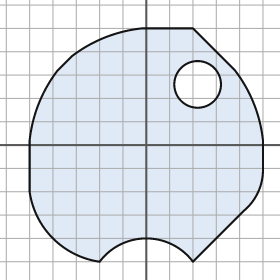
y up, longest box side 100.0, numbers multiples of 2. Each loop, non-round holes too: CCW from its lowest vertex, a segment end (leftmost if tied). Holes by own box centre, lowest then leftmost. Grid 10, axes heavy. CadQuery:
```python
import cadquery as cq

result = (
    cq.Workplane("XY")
    .moveTo(-20.0, -50.0)
    .threePointArc((0.0, -40.0), (20.0, -50.0))
    .lineTo(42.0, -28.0)
    .threePointArc((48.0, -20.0), (50.0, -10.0))
    .lineTo(50.0, 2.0)
    .threePointArc((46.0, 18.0), (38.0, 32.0))
    .lineTo(20.0, 50.0)
    .lineTo(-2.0, 50.0)
    .threePointArc((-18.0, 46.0), (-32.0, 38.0))
    .lineTo(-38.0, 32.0)
    .threePointArc((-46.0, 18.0), (-50.0, 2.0))
    .lineTo(-50.0, -20.0)
    .threePointArc((-40.0, -40.0), (-20.0, -50.0))
    .close()
    .moveTo(22.0, 26.0)
    .circle(10.0)
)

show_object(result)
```